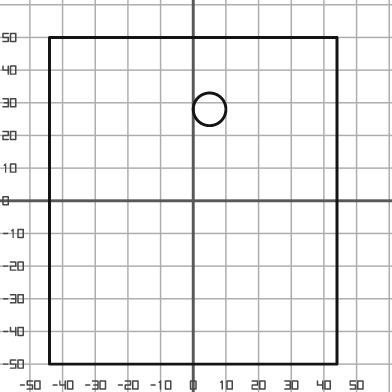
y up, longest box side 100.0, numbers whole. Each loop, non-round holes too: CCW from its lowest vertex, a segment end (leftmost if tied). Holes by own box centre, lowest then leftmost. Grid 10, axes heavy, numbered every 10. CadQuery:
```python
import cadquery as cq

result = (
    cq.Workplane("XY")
    .moveTo(-44.0, -50.0)
    .lineTo(44.0, -50.0)
    .lineTo(44.0, 50.0)
    .lineTo(-44.0, 50.0)
    .close()
    .moveTo(5.0, 28.0)
    .circle(5.0)
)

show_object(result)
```